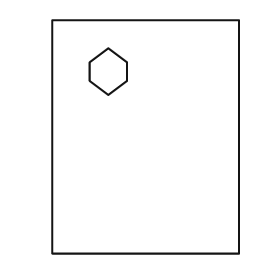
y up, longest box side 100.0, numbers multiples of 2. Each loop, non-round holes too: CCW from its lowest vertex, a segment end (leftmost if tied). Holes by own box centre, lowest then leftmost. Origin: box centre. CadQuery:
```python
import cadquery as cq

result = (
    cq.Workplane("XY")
    .moveTo(-40.0, -50.0)
    .lineTo(40.0, -50.0)
    .lineTo(40.0, 50.0)
    .lineTo(-40.0, 50.0)
    .close()
    .moveTo(-16.0, 18.0)
    .lineTo(-8.0, 24.0)
    .lineTo(-8.0, 32.0)
    .lineTo(-16.0, 38.0)
    .lineTo(-24.0, 32.0)
    .lineTo(-24.0, 24.0)
    .close()
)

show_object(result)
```